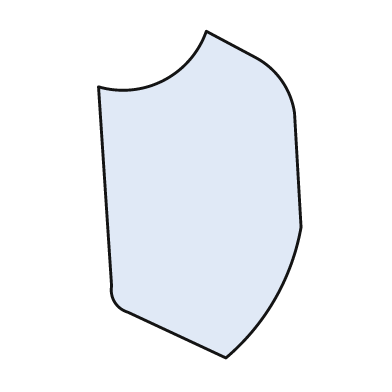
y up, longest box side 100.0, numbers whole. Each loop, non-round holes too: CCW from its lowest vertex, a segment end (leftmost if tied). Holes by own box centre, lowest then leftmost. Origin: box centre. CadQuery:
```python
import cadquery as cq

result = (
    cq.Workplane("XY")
    .moveTo(8.0, -50.0)
    .threePointArc((23.0, -32.0), (31.0, -10.0))
    .lineTo(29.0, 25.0)
    .threePointArc((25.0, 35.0), (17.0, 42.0))
    .lineTo(2.0, 50.0)
    .threePointArc((-11.0, 35.0), (-31.0, 33.0))
    .lineTo(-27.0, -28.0)
    .threePointArc((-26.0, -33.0), (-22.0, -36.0))
    .close()
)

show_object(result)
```